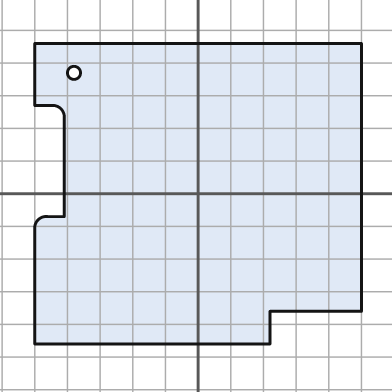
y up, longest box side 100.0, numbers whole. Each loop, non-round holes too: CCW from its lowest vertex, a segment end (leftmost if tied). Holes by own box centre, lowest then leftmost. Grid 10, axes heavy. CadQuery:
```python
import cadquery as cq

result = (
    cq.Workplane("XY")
    .moveTo(-50.0, -46.0)
    .lineTo(22.0, -46.0)
    .lineTo(22.0, -36.0)
    .lineTo(50.0, -36.0)
    .lineTo(50.0, 46.0)
    .lineTo(-50.0, 46.0)
    .lineTo(-50.0, 27.0)
    .lineTo(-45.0, 27.0)
    .threePointArc((-42.0, 26.0), (-41.0, 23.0))
    .lineTo(-41.0, -7.0)
    .lineTo(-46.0, -7.0)
    .threePointArc((-49.0, -8.0), (-50.0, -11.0))
    .close()
    .moveTo(-38.0, 37.0)
    .circle(2.0)
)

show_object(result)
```